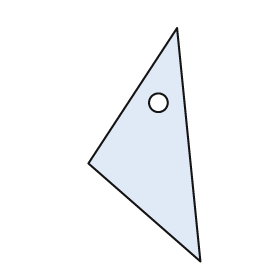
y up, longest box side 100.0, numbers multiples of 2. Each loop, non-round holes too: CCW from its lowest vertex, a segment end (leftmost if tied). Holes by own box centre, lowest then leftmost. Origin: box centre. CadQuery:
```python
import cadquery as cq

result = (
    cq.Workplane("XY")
    .moveTo(24.0, -50.0)
    .lineTo(14.0, 50.0)
    .lineTo(-24.0, -8.0)
    .close()
    .moveTo(6.0, 18.0)
    .circle(4.0)
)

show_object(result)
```